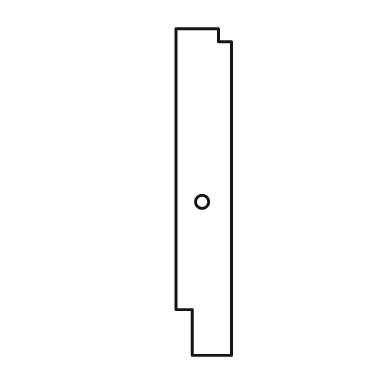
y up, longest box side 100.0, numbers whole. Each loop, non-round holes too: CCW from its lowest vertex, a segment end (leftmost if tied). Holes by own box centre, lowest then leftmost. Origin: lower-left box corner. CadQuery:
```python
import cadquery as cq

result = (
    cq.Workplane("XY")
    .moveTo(5.0, 0.0)
    .lineTo(17.0, 0.0)
    .lineTo(17.0, 96.0)
    .lineTo(13.0, 96.0)
    .lineTo(13.0, 100.0)
    .lineTo(0.0, 100.0)
    .lineTo(0.0, 14.0)
    .lineTo(5.0, 14.0)
    .close()
    .moveTo(8.0, 47.0)
    .circle(2.0)
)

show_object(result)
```